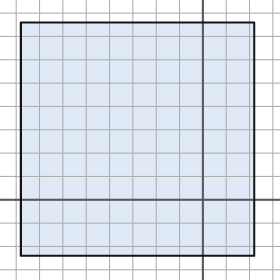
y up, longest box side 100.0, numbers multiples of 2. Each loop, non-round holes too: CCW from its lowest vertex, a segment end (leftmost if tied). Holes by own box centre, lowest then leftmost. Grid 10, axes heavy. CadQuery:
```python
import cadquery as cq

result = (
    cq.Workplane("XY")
    .moveTo(-78.0, -24.0)
    .lineTo(22.0, -24.0)
    .lineTo(22.0, 76.0)
    .lineTo(-78.0, 76.0)
    .close()
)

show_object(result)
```